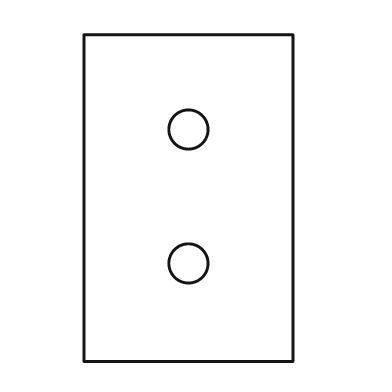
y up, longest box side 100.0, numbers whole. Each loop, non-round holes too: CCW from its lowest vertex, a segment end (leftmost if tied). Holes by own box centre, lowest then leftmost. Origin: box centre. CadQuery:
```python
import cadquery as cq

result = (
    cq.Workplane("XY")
    .moveTo(-32.0, -50.0)
    .lineTo(32.0, -50.0)
    .lineTo(32.0, 50.0)
    .lineTo(-32.0, 50.0)
    .close()
    .moveTo(0.0, -20.0)
    .circle(6.0)
    .moveTo(0.0, 21.0)
    .circle(6.0)
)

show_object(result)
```